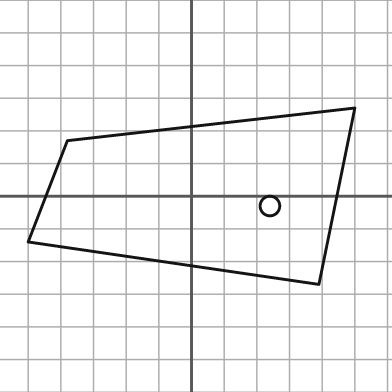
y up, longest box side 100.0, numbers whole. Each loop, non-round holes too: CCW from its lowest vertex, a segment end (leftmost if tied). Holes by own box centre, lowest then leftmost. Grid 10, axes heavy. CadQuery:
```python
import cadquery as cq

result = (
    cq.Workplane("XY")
    .moveTo(39.0, -27.0)
    .lineTo(50.0, 27.0)
    .lineTo(-38.0, 17.0)
    .lineTo(-50.0, -14.0)
    .close()
    .moveTo(24.0, -3.0)
    .circle(3.0)
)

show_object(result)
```